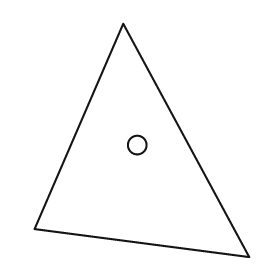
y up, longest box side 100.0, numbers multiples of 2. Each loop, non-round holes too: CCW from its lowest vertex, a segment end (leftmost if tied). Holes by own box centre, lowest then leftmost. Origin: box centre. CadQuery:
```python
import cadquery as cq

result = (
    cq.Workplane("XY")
    .moveTo(46.0, -50.0)
    .lineTo(-8.0, 50.0)
    .lineTo(-46.0, -38.0)
    .close()
    .moveTo(-2.0, -2.0)
    .circle(4.0)
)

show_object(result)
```